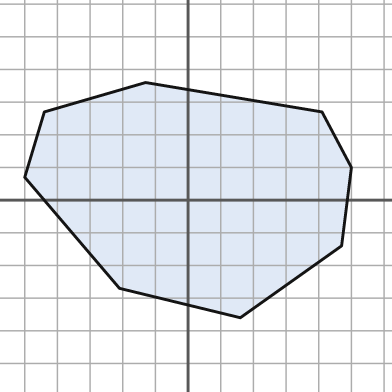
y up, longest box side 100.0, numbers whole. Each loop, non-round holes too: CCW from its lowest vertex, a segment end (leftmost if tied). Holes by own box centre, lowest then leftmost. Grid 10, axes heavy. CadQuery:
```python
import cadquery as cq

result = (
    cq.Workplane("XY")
    .moveTo(16.0, -36.0)
    .lineTo(47.0, -14.0)
    .lineTo(50.0, 10.0)
    .lineTo(41.0, 27.0)
    .lineTo(-13.0, 36.0)
    .lineTo(-44.0, 27.0)
    .lineTo(-50.0, 7.0)
    .lineTo(-21.0, -27.0)
    .close()
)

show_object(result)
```